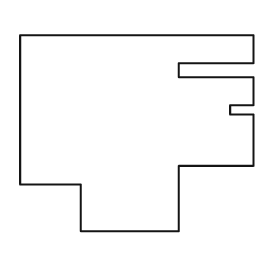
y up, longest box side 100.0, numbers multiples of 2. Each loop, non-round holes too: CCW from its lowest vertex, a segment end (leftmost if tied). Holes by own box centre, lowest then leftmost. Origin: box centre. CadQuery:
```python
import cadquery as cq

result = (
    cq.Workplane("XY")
    .moveTo(-24.0, -42.0)
    .lineTo(18.0, -42.0)
    .lineTo(18.0, -14.0)
    .lineTo(50.0, -14.0)
    .lineTo(50.0, 8.0)
    .lineTo(40.0, 8.0)
    .lineTo(40.0, 12.0)
    .lineTo(50.0, 12.0)
    .lineTo(50.0, 24.0)
    .lineTo(18.0, 24.0)
    .lineTo(18.0, 30.0)
    .lineTo(50.0, 30.0)
    .lineTo(50.0, 42.0)
    .lineTo(-50.0, 42.0)
    .lineTo(-50.0, -22.0)
    .lineTo(-24.0, -22.0)
    .close()
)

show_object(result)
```